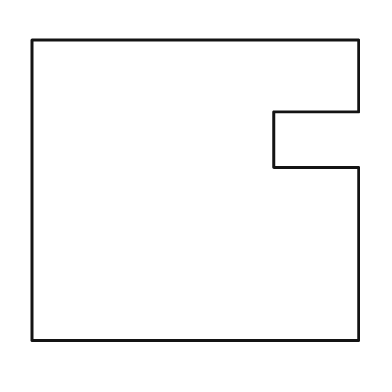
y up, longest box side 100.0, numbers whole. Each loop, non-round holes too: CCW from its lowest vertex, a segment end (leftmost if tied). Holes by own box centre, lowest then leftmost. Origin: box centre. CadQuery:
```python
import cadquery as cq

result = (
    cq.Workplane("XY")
    .moveTo(-50.0, -46.0)
    .lineTo(50.0, -46.0)
    .lineTo(50.0, 7.0)
    .lineTo(24.0, 7.0)
    .lineTo(24.0, 24.0)
    .lineTo(50.0, 24.0)
    .lineTo(50.0, 46.0)
    .lineTo(-50.0, 46.0)
    .close()
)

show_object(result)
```